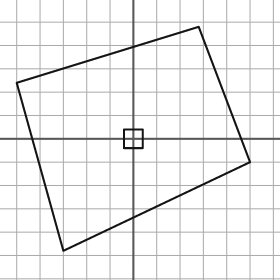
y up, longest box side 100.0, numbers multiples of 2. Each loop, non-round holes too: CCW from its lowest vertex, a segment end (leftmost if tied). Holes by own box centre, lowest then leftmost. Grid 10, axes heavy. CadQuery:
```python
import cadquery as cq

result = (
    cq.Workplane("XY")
    .moveTo(-30.0, -48.0)
    .lineTo(50.0, -10.0)
    .lineTo(28.0, 48.0)
    .lineTo(-50.0, 24.0)
    .close()
    .moveTo(-4.0, -4.0)
    .lineTo(4.0, -4.0)
    .lineTo(4.0, 4.0)
    .lineTo(-4.0, 4.0)
    .close()
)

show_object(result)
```